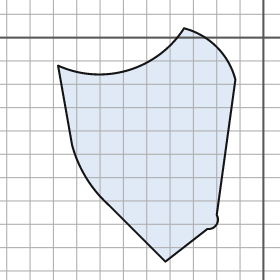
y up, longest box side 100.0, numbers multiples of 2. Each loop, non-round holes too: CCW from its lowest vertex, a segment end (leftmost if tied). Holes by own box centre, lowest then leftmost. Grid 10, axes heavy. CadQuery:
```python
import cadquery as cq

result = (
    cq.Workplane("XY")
    .moveTo(-42.0, -96.0)
    .lineTo(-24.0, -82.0)
    .threePointArc((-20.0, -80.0), (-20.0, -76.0))
    .lineTo(-12.0, -18.0)
    .threePointArc((-20.0, -4.0), (-34.0, 4.0))
    .threePointArc((-58.0, -14.0), (-88.0, -12.0))
    .lineTo(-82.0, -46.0)
    .threePointArc((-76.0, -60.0), (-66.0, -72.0))
    .close()
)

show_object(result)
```